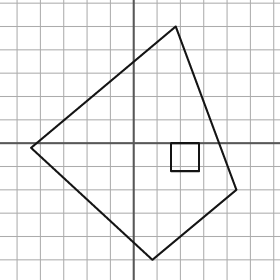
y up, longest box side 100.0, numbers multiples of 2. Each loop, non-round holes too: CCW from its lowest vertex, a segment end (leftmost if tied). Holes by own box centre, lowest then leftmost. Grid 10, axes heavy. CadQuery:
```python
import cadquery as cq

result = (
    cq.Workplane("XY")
    .moveTo(8.0, -50.0)
    .lineTo(44.0, -20.0)
    .lineTo(18.0, 50.0)
    .lineTo(-44.0, -2.0)
    .close()
    .moveTo(16.0, -12.0)
    .lineTo(28.0, -12.0)
    .lineTo(28.0, 0.0)
    .lineTo(16.0, 0.0)
    .close()
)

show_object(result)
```